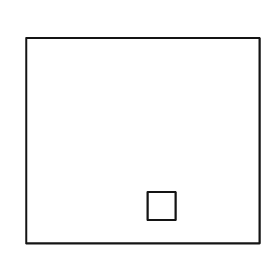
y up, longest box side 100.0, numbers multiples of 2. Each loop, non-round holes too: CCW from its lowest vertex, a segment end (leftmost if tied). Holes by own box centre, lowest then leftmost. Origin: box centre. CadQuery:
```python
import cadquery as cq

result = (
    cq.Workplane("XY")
    .moveTo(-50.0, -44.0)
    .lineTo(50.0, -44.0)
    .lineTo(50.0, 44.0)
    .lineTo(-50.0, 44.0)
    .close()
    .moveTo(2.0, -34.0)
    .lineTo(14.0, -34.0)
    .lineTo(14.0, -22.0)
    .lineTo(2.0, -22.0)
    .close()
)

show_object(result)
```